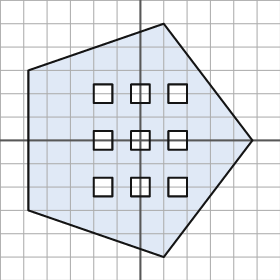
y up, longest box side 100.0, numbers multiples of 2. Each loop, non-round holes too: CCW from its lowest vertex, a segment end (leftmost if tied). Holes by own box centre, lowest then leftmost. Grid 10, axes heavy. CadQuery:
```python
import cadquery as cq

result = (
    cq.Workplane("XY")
    .moveTo(10.0, -50.0)
    .lineTo(48.0, 0.0)
    .lineTo(10.0, 50.0)
    .lineTo(-48.0, 30.0)
    .lineTo(-48.0, -30.0)
    .close()
    .moveTo(-20.0, -24.0)
    .lineTo(-12.0, -24.0)
    .lineTo(-12.0, -16.0)
    .lineTo(-20.0, -16.0)
    .close()
    .moveTo(-4.0, -24.0)
    .lineTo(4.0, -24.0)
    .lineTo(4.0, -16.0)
    .lineTo(-4.0, -16.0)
    .close()
    .moveTo(12.0, -24.0)
    .lineTo(20.0, -24.0)
    .lineTo(20.0, -16.0)
    .lineTo(12.0, -16.0)
    .close()
    .moveTo(-20.0, -4.0)
    .lineTo(-12.0, -4.0)
    .lineTo(-12.0, 4.0)
    .lineTo(-20.0, 4.0)
    .close()
    .moveTo(-4.0, -4.0)
    .lineTo(4.0, -4.0)
    .lineTo(4.0, 4.0)
    .lineTo(-4.0, 4.0)
    .close()
    .moveTo(12.0, -4.0)
    .lineTo(20.0, -4.0)
    .lineTo(20.0, 4.0)
    .lineTo(12.0, 4.0)
    .close()
    .moveTo(-20.0, 16.0)
    .lineTo(-12.0, 16.0)
    .lineTo(-12.0, 24.0)
    .lineTo(-20.0, 24.0)
    .close()
    .moveTo(-4.0, 16.0)
    .lineTo(4.0, 16.0)
    .lineTo(4.0, 24.0)
    .lineTo(-4.0, 24.0)
    .close()
    .moveTo(12.0, 16.0)
    .lineTo(20.0, 16.0)
    .lineTo(20.0, 24.0)
    .lineTo(12.0, 24.0)
    .close()
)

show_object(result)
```